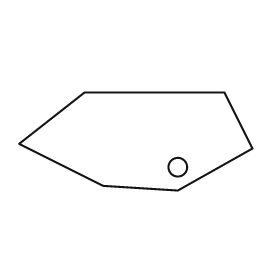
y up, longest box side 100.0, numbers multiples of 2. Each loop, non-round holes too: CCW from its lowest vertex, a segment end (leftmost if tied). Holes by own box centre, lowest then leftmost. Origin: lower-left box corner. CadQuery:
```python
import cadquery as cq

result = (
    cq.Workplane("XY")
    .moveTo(68.0, 0.0)
    .lineTo(100.0, 18.0)
    .lineTo(88.0, 42.0)
    .lineTo(28.0, 42.0)
    .lineTo(0.0, 20.0)
    .lineTo(36.0, 2.0)
    .close()
    .moveTo(68.0, 10.0)
    .circle(4.0)
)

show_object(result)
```